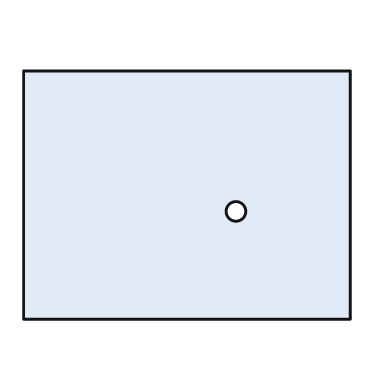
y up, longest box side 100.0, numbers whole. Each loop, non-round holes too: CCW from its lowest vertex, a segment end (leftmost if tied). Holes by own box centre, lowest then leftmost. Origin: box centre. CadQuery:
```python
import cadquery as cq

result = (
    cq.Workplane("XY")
    .moveTo(-50.0, -38.0)
    .lineTo(50.0, -38.0)
    .lineTo(50.0, 38.0)
    .lineTo(-50.0, 38.0)
    .close()
    .moveTo(15.0, -5.0)
    .circle(3.0)
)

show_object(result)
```